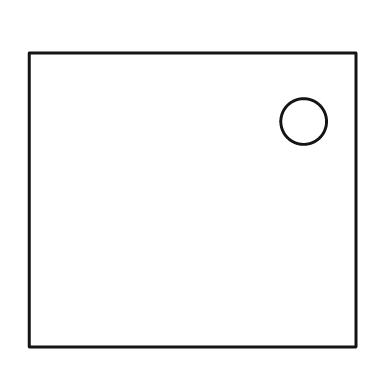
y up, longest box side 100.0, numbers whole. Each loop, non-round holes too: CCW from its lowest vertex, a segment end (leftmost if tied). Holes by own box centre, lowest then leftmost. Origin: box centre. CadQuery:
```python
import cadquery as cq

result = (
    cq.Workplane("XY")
    .moveTo(-50.0, -45.0)
    .lineTo(50.0, -45.0)
    .lineTo(50.0, 45.0)
    .lineTo(-50.0, 45.0)
    .close()
    .moveTo(34.0, 24.0)
    .circle(7.0)
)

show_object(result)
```